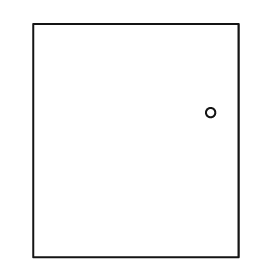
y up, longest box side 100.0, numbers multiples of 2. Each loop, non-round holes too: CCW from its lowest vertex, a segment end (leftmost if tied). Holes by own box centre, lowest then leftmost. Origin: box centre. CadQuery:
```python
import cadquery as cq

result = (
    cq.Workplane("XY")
    .moveTo(-44.0, -50.0)
    .lineTo(44.0, -50.0)
    .lineTo(44.0, 50.0)
    .lineTo(-44.0, 50.0)
    .close()
    .moveTo(32.0, 12.0)
    .circle(2.0)
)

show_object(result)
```